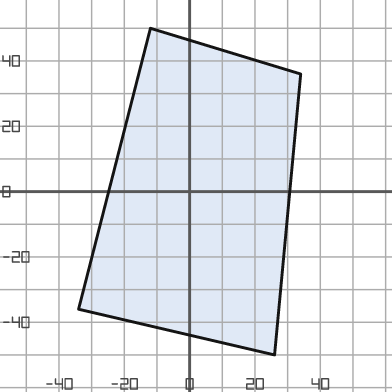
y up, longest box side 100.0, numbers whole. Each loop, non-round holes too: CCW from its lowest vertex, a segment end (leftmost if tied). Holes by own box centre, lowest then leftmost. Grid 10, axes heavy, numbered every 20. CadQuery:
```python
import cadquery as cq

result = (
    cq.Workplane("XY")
    .moveTo(26.0, -50.0)
    .lineTo(34.0, 36.0)
    .lineTo(-12.0, 50.0)
    .lineTo(-34.0, -36.0)
    .close()
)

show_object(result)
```